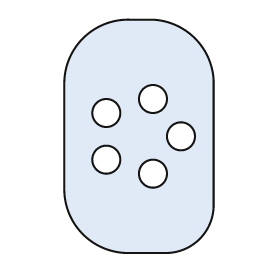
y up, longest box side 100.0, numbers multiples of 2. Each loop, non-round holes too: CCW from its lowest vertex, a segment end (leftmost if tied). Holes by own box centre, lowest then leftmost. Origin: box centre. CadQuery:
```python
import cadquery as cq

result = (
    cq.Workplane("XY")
    .moveTo(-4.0, -50.0)
    .lineTo(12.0, -50.0)
    .threePointArc((26.0, -44.0), (32.0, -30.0))
    .lineTo(32.0, 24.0)
    .threePointArc((24.0, 42.0), (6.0, 50.0))
    .lineTo(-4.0, 50.0)
    .threePointArc((-24.0, 42.0), (-32.0, 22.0))
    .lineTo(-32.0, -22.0)
    .threePointArc((-24.0, -42.0), (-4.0, -50.0))
    .close()
    .moveTo(6.0, -16.0)
    .circle(6.0)
    .moveTo(-14.0, -10.0)
    .circle(6.0)
    .moveTo(18.0, 0.0)
    .circle(6.0)
    .moveTo(-14.0, 10.0)
    .circle(6.0)
    .moveTo(6.0, 16.0)
    .circle(6.0)
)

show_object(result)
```